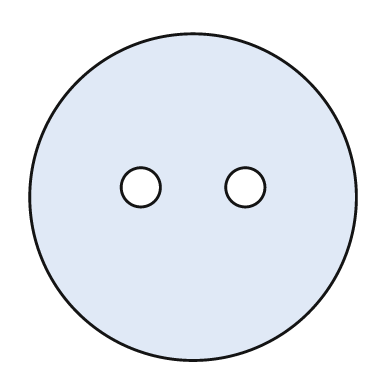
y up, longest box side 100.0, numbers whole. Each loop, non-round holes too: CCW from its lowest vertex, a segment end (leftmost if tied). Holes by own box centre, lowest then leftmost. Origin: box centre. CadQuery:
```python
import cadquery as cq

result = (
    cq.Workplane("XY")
    .moveTo(0.0, 0.0)
    .circle(50.0)
    .moveTo(-16.0, 3.0)
    .circle(6.0)
    .moveTo(16.0, 3.0)
    .circle(6.0)
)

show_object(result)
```